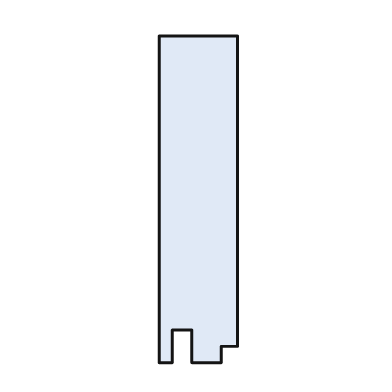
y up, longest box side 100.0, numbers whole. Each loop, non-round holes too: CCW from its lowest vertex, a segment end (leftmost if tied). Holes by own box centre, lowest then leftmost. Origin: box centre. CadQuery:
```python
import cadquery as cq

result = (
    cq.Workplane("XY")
    .moveTo(-12.0, -50.0)
    .lineTo(-8.0, -50.0)
    .lineTo(-8.0, -40.0)
    .lineTo(-2.0, -40.0)
    .lineTo(-2.0, -50.0)
    .lineTo(7.0, -50.0)
    .lineTo(7.0, -45.0)
    .lineTo(12.0, -45.0)
    .lineTo(12.0, 50.0)
    .lineTo(-12.0, 50.0)
    .close()
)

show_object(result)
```